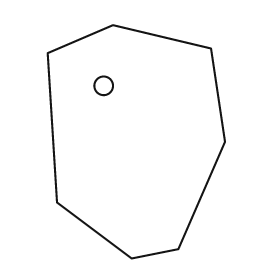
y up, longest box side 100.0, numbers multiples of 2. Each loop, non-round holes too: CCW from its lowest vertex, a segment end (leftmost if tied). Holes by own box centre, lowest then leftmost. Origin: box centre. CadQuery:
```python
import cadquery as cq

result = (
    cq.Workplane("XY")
    .moveTo(-2.0, -50.0)
    .lineTo(18.0, -46.0)
    .lineTo(38.0, 0.0)
    .lineTo(32.0, 40.0)
    .lineTo(-10.0, 50.0)
    .lineTo(-38.0, 38.0)
    .lineTo(-34.0, -26.0)
    .close()
    .moveTo(-14.0, 24.0)
    .circle(4.0)
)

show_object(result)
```